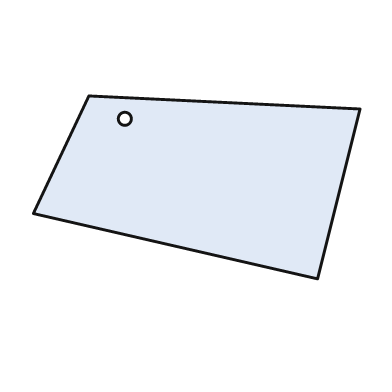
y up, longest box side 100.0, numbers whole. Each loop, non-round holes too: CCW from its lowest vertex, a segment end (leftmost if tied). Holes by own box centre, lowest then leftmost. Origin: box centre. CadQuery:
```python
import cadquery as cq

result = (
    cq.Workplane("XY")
    .moveTo(37.0, -28.0)
    .lineTo(50.0, 24.0)
    .lineTo(-33.0, 28.0)
    .lineTo(-50.0, -8.0)
    .close()
    .moveTo(-22.0, 21.0)
    .circle(2.0)
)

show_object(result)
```